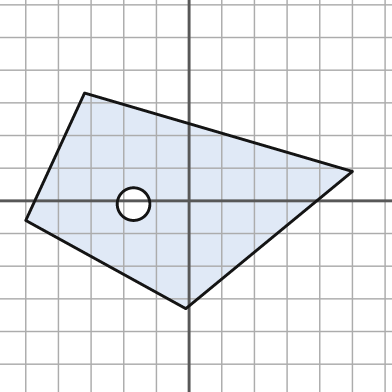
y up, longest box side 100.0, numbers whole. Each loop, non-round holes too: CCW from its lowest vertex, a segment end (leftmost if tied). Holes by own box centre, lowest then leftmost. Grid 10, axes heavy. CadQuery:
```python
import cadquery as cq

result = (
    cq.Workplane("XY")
    .moveTo(-1.0, -33.0)
    .lineTo(50.0, 9.0)
    .lineTo(-32.0, 33.0)
    .lineTo(-50.0, -6.0)
    .close()
    .moveTo(-17.0, -1.0)
    .circle(5.0)
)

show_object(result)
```